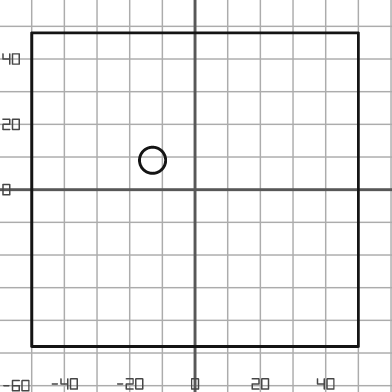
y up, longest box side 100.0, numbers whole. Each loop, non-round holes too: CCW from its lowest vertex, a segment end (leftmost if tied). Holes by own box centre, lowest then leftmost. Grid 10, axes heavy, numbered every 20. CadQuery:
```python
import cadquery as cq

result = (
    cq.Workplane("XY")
    .moveTo(-50.0, -48.0)
    .lineTo(50.0, -48.0)
    .lineTo(50.0, 48.0)
    .lineTo(-50.0, 48.0)
    .close()
    .moveTo(-13.0, 9.0)
    .circle(4.0)
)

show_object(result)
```